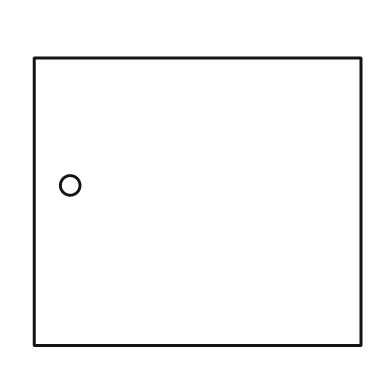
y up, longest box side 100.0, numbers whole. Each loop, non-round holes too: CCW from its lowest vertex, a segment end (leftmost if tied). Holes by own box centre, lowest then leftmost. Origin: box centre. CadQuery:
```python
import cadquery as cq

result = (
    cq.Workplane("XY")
    .moveTo(-50.0, -44.0)
    .lineTo(50.0, -44.0)
    .lineTo(50.0, 44.0)
    .lineTo(-50.0, 44.0)
    .close()
    .moveTo(-39.0, 5.0)
    .circle(3.0)
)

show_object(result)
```